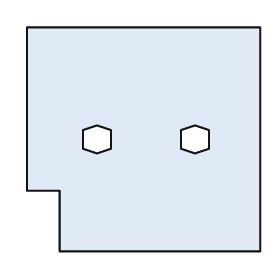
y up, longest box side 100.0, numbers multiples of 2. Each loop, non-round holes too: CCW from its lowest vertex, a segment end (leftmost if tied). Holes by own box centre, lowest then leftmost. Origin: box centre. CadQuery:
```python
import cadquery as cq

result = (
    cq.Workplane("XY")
    .moveTo(-36.0, -48.0)
    .lineTo(50.0, -48.0)
    .lineTo(50.0, 48.0)
    .lineTo(-50.0, 48.0)
    .lineTo(-50.0, -22.0)
    .lineTo(-36.0, -22.0)
    .close()
    .moveTo(-20.0, -6.0)
    .lineTo(-14.0, -4.0)
    .lineTo(-14.0, 4.0)
    .lineTo(-20.0, 6.0)
    .lineTo(-26.0, 4.0)
    .lineTo(-26.0, -4.0)
    .close()
    .moveTo(22.0, -6.0)
    .lineTo(28.0, -4.0)
    .lineTo(28.0, 4.0)
    .lineTo(22.0, 6.0)
    .lineTo(16.0, 4.0)
    .lineTo(16.0, -4.0)
    .close()
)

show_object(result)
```